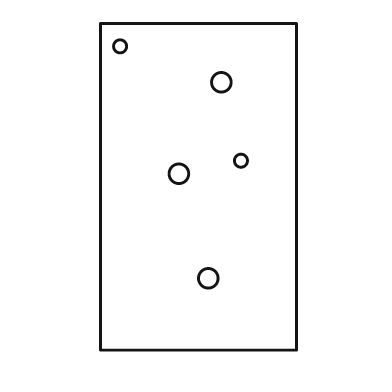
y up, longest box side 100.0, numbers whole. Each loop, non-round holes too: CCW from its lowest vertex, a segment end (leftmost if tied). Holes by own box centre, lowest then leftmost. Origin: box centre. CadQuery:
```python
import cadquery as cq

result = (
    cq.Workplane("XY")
    .moveTo(-30.0, -50.0)
    .lineTo(30.0, -50.0)
    .lineTo(30.0, 50.0)
    .lineTo(-30.0, 50.0)
    .close()
    .moveTo(3.0, -28.0)
    .circle(3.0)
    .moveTo(-6.0, 4.0)
    .circle(3.0)
    .moveTo(13.0, 8.0)
    .circle(2.0)
    .moveTo(7.0, 32.0)
    .circle(3.0)
    .moveTo(-24.0, 43.0)
    .circle(2.0)
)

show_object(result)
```